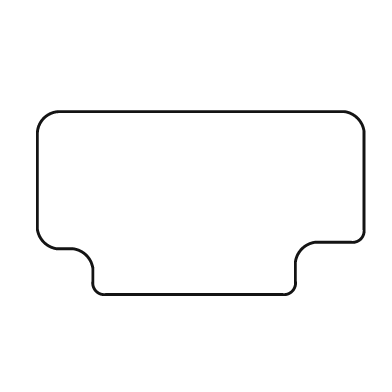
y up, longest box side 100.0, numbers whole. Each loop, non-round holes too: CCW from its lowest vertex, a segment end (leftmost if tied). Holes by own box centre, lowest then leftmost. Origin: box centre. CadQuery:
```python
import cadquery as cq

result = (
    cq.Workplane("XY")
    .moveTo(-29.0, -28.0)
    .lineTo(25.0, -28.0)
    .threePointArc((28.0, -27.0), (29.0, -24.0))
    .lineTo(29.0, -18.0)
    .threePointArc((31.0, -14.0), (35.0, -12.0))
    .lineTo(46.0, -12.0)
    .threePointArc((49.0, -11.0), (50.0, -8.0))
    .lineTo(50.0, 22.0)
    .threePointArc((48.0, 26.0), (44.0, 28.0))
    .lineTo(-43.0, 28.0)
    .threePointArc((-48.0, 26.0), (-50.0, 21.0))
    .lineTo(-50.0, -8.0)
    .threePointArc((-48.0, -12.0), (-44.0, -14.0))
    .lineTo(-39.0, -14.0)
    .threePointArc((-35.0, -16.0), (-33.0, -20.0))
    .lineTo(-33.0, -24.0)
    .threePointArc((-32.0, -27.0), (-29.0, -28.0))
    .close()
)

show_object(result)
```